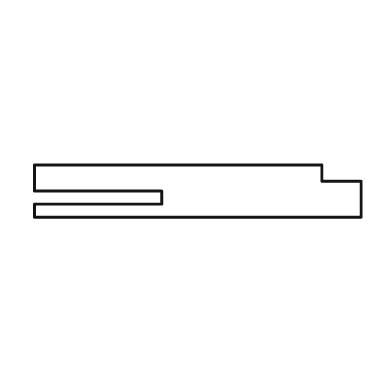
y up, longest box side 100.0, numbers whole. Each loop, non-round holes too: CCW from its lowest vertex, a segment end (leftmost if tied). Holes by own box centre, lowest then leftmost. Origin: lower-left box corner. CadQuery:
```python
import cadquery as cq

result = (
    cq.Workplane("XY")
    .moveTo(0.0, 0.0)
    .lineTo(100.0, 0.0)
    .lineTo(100.0, 11.0)
    .lineTo(88.0, 11.0)
    .lineTo(88.0, 16.0)
    .lineTo(0.0, 16.0)
    .lineTo(0.0, 8.0)
    .lineTo(39.0, 8.0)
    .lineTo(39.0, 4.0)
    .lineTo(0.0, 4.0)
    .close()
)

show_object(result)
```